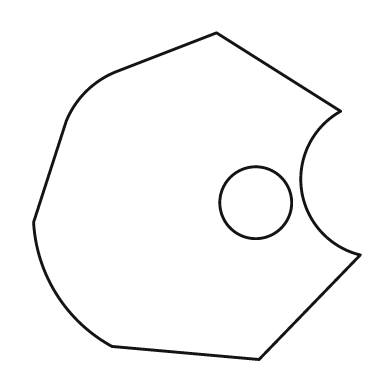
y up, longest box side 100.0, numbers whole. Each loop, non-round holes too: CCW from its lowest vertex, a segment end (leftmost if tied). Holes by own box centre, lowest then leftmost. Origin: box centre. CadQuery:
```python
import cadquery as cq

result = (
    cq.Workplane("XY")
    .moveTo(19.0, -50.0)
    .lineTo(50.0, -18.0)
    .threePointArc((32.0, 2.0), (44.0, 26.0))
    .lineTo(6.0, 50.0)
    .lineTo(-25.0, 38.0)
    .threePointArc((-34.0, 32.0), (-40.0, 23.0))
    .lineTo(-50.0, -8.0)
    .threePointArc((-43.0, -30.0), (-26.0, -46.0))
    .close()
    .moveTo(18.0, -2.0)
    .circle(11.0)
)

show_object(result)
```